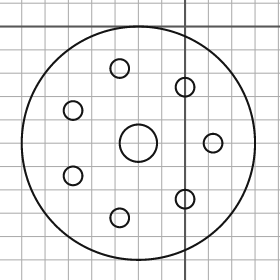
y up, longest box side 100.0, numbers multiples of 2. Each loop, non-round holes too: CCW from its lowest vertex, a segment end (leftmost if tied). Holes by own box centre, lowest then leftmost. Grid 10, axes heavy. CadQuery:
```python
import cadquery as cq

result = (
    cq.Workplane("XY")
    .moveTo(-20.0, -50.0)
    .circle(50.0)
    .moveTo(-28.0, -82.0)
    .circle(4.0)
    .moveTo(0.0, -74.0)
    .circle(4.0)
    .moveTo(-48.0, -64.0)
    .circle(4.0)
    .moveTo(-20.0, -50.0)
    .circle(8.0)
    .moveTo(12.0, -50.0)
    .circle(4.0)
    .moveTo(-48.0, -36.0)
    .circle(4.0)
    .moveTo(0.0, -26.0)
    .circle(4.0)
    .moveTo(-28.0, -18.0)
    .circle(4.0)
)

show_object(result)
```